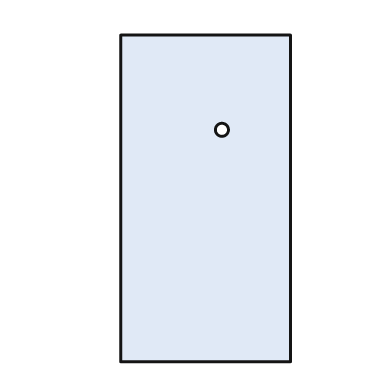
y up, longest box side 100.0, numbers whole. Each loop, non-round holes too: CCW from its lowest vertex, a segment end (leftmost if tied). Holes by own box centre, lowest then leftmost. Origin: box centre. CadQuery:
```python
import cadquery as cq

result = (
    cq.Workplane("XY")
    .moveTo(-26.0, -50.0)
    .lineTo(26.0, -50.0)
    .lineTo(26.0, 50.0)
    .lineTo(-26.0, 50.0)
    .close()
    .moveTo(5.0, 21.0)
    .circle(2.0)
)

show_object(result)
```